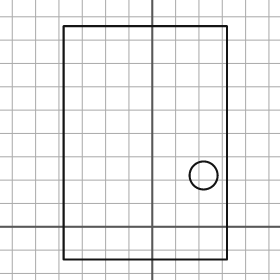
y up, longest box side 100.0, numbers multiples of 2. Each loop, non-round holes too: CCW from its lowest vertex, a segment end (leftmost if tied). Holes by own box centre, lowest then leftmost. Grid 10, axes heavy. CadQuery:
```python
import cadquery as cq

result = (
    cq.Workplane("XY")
    .moveTo(-38.0, -14.0)
    .lineTo(32.0, -14.0)
    .lineTo(32.0, 86.0)
    .lineTo(-38.0, 86.0)
    .close()
    .moveTo(22.0, 22.0)
    .circle(6.0)
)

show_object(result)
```